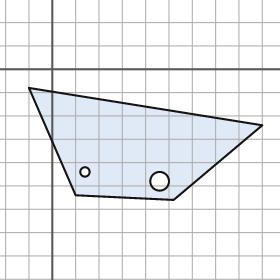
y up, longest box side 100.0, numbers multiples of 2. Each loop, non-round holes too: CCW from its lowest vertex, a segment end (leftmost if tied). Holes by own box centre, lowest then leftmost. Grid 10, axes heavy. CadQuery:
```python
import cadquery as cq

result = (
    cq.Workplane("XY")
    .moveTo(52.0, -56.0)
    .lineTo(90.0, -24.0)
    .lineTo(-10.0, -8.0)
    .lineTo(10.0, -54.0)
    .close()
    .moveTo(46.0, -48.0)
    .circle(4.0)
    .moveTo(14.0, -44.0)
    .circle(2.0)
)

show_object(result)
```